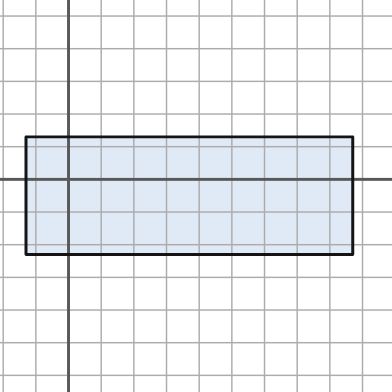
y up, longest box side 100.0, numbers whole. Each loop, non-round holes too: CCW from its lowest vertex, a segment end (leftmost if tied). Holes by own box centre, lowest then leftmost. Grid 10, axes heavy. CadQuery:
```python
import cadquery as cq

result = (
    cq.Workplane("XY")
    .moveTo(-13.0, -23.0)
    .lineTo(87.0, -23.0)
    .lineTo(87.0, 13.0)
    .lineTo(-13.0, 13.0)
    .close()
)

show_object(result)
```